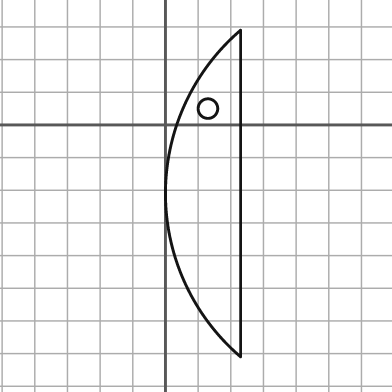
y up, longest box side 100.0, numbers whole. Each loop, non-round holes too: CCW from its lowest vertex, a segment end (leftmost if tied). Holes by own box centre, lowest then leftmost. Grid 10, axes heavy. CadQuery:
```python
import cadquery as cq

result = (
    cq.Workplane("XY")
    .moveTo(23.0, -71.0)
    .lineTo(23.0, 29.0)
    .threePointArc((0.0, -21.0), (23.0, -71.0))
    .close()
    .moveTo(13.0, 5.0)
    .circle(3.0)
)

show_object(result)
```